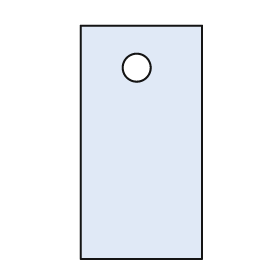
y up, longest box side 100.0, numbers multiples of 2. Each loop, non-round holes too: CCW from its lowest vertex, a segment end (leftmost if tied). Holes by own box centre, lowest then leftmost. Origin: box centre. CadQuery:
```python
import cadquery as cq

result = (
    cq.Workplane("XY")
    .moveTo(-26.0, -50.0)
    .lineTo(26.0, -50.0)
    .lineTo(26.0, 50.0)
    .lineTo(-26.0, 50.0)
    .close()
    .moveTo(-2.0, 32.0)
    .circle(6.0)
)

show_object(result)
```